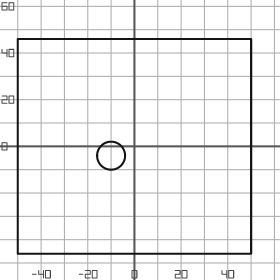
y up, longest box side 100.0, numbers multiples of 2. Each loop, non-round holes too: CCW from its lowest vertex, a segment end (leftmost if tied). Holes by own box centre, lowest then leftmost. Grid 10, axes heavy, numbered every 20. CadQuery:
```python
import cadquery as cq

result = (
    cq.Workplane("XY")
    .moveTo(-50.0, -46.0)
    .lineTo(50.0, -46.0)
    .lineTo(50.0, 46.0)
    .lineTo(-50.0, 46.0)
    .close()
    .moveTo(-10.0, -4.0)
    .circle(6.0)
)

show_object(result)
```